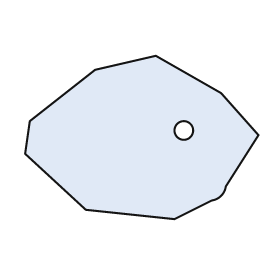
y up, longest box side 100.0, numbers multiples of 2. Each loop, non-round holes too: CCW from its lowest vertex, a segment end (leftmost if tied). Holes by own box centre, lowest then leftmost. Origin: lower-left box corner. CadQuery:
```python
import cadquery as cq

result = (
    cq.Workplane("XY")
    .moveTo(64.0, 0.0)
    .lineTo(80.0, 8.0)
    .threePointArc((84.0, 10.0), (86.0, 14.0))
    .lineTo(100.0, 36.0)
    .lineTo(84.0, 54.0)
    .lineTo(56.0, 70.0)
    .lineTo(30.0, 64.0)
    .lineTo(2.0, 42.0)
    .lineTo(0.0, 28.0)
    .lineTo(26.0, 4.0)
    .close()
    .moveTo(68.0, 38.0)
    .circle(4.0)
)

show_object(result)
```